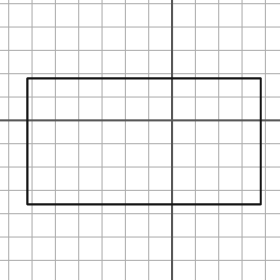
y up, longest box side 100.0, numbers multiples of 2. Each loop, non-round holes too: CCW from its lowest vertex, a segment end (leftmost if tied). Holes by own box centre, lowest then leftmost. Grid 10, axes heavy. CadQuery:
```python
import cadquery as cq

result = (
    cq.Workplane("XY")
    .moveTo(-62.0, -36.0)
    .lineTo(38.0, -36.0)
    .lineTo(38.0, 18.0)
    .lineTo(-62.0, 18.0)
    .close()
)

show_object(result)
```